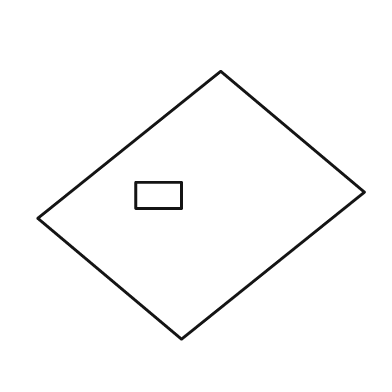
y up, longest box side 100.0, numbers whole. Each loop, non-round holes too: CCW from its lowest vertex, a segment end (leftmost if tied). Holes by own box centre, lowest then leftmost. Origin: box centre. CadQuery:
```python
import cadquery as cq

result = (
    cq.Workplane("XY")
    .moveTo(-6.0, -41.0)
    .lineTo(50.0, 4.0)
    .lineTo(6.0, 41.0)
    .lineTo(-50.0, -4.0)
    .close()
    .moveTo(-20.0, -1.0)
    .lineTo(-6.0, -1.0)
    .lineTo(-6.0, 7.0)
    .lineTo(-20.0, 7.0)
    .close()
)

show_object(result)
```